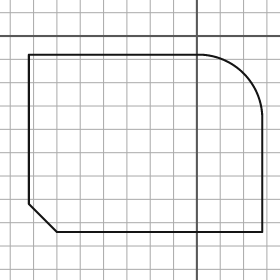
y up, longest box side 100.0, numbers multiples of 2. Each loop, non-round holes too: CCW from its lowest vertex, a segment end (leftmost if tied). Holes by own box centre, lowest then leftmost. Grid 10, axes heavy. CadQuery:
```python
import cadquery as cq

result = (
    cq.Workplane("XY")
    .moveTo(-60.0, -84.0)
    .lineTo(28.0, -84.0)
    .lineTo(28.0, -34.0)
    .threePointArc((20.0, -16.0), (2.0, -8.0))
    .lineTo(-72.0, -8.0)
    .lineTo(-72.0, -72.0)
    .close()
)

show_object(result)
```